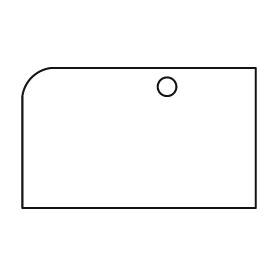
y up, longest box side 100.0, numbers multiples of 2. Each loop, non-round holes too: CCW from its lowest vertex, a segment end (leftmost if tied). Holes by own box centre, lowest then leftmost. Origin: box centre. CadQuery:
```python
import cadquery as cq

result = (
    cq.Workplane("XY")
    .moveTo(-50.0, -30.0)
    .lineTo(50.0, -30.0)
    .lineTo(50.0, 30.0)
    .lineTo(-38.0, 30.0)
    .threePointArc((-46.0, 26.0), (-50.0, 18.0))
    .close()
    .moveTo(12.0, 22.0)
    .circle(4.0)
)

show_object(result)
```